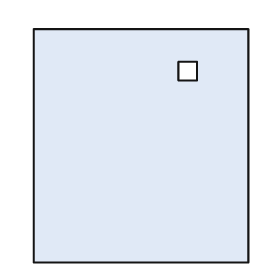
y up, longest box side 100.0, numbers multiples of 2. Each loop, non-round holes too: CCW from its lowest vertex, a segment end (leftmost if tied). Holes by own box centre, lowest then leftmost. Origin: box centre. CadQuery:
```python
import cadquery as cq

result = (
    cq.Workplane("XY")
    .moveTo(-46.0, -50.0)
    .lineTo(46.0, -50.0)
    .lineTo(46.0, 50.0)
    .lineTo(-46.0, 50.0)
    .close()
    .moveTo(16.0, 28.0)
    .lineTo(24.0, 28.0)
    .lineTo(24.0, 36.0)
    .lineTo(16.0, 36.0)
    .close()
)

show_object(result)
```